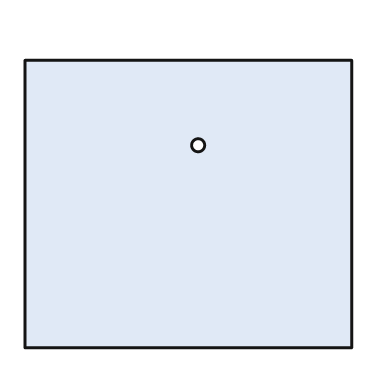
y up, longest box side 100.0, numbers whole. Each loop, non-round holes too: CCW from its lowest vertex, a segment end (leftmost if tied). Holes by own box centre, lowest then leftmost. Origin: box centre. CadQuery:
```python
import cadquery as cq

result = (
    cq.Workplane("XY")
    .moveTo(-50.0, -44.0)
    .lineTo(50.0, -44.0)
    .lineTo(50.0, 44.0)
    .lineTo(-50.0, 44.0)
    .close()
    .moveTo(3.0, 18.0)
    .circle(2.0)
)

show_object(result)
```